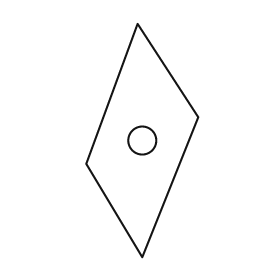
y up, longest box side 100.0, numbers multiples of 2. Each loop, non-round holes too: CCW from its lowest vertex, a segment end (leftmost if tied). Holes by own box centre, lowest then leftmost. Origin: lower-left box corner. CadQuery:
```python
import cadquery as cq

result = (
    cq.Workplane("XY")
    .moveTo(24.0, 0.0)
    .lineTo(48.0, 60.0)
    .lineTo(22.0, 100.0)
    .lineTo(0.0, 40.0)
    .close()
    .moveTo(24.0, 50.0)
    .circle(6.0)
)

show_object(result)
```